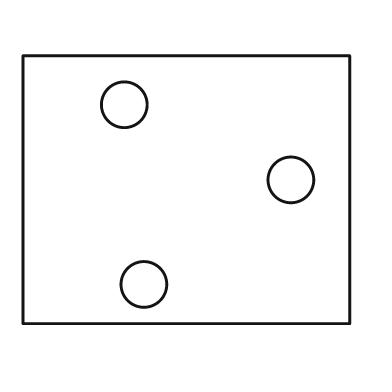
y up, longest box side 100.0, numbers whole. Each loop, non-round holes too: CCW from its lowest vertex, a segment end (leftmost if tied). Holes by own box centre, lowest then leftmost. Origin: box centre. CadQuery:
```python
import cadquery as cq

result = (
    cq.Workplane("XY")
    .moveTo(-50.0, -41.0)
    .lineTo(50.0, -41.0)
    .lineTo(50.0, 41.0)
    .lineTo(-50.0, 41.0)
    .close()
    .moveTo(-13.0, -29.0)
    .circle(7.0)
    .moveTo(32.0, 3.0)
    .circle(7.0)
    .moveTo(-19.0, 26.0)
    .circle(7.0)
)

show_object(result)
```